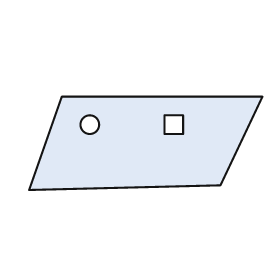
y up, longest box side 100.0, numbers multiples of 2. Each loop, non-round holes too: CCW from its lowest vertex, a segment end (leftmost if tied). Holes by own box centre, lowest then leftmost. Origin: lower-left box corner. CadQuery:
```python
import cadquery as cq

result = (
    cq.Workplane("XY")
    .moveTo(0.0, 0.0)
    .lineTo(82.0, 2.0)
    .lineTo(100.0, 40.0)
    .lineTo(14.0, 40.0)
    .close()
    .moveTo(26.0, 28.0)
    .circle(4.0)
    .moveTo(58.0, 24.0)
    .lineTo(66.0, 24.0)
    .lineTo(66.0, 32.0)
    .lineTo(58.0, 32.0)
    .close()
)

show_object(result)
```